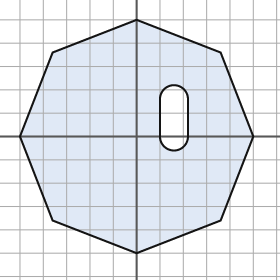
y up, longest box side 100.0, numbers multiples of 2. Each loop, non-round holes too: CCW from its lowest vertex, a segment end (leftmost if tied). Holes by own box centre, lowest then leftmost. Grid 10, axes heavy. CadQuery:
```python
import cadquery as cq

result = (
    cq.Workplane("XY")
    .moveTo(0.0, -50.0)
    .lineTo(36.0, -36.0)
    .lineTo(50.0, 0.0)
    .lineTo(36.0, 36.0)
    .lineTo(0.0, 50.0)
    .lineTo(-36.0, 36.0)
    .lineTo(-50.0, 0.0)
    .lineTo(-36.0, -36.0)
    .close()
    .moveTo(10.0, 0.0)
    .threePointArc((16.0, -6.0), (22.0, 0.0))
    .lineTo(22.0, 16.0)
    .threePointArc((16.0, 22.0), (10.0, 16.0))
    .close()
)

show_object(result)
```